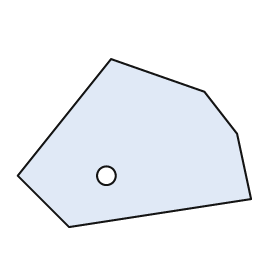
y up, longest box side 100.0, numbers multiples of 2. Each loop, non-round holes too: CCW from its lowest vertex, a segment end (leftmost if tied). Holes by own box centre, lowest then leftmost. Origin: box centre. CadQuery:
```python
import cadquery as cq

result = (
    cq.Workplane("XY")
    .moveTo(-28.0, -36.0)
    .lineTo(50.0, -24.0)
    .lineTo(44.0, 4.0)
    .lineTo(30.0, 22.0)
    .lineTo(-10.0, 36.0)
    .lineTo(-50.0, -14.0)
    .close()
    .moveTo(-12.0, -14.0)
    .circle(4.0)
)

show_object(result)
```